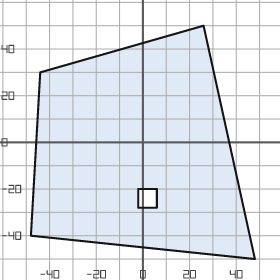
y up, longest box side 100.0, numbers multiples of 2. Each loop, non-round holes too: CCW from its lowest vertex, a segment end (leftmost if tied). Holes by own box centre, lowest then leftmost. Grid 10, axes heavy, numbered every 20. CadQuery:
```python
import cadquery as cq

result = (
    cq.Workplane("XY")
    .moveTo(48.0, -50.0)
    .lineTo(26.0, 50.0)
    .lineTo(-44.0, 30.0)
    .lineTo(-48.0, -40.0)
    .close()
    .moveTo(-2.0, -28.0)
    .lineTo(6.0, -28.0)
    .lineTo(6.0, -20.0)
    .lineTo(-2.0, -20.0)
    .close()
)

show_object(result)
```